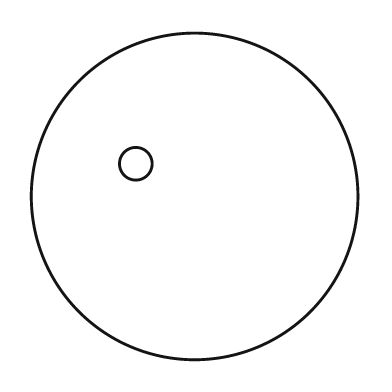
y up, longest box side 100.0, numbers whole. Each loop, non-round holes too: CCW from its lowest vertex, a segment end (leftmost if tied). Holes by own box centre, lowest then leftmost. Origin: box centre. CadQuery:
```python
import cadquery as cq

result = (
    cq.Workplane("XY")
    .moveTo(0.0, 0.0)
    .circle(50.0)
    .moveTo(-18.0, 10.0)
    .circle(5.0)
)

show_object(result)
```